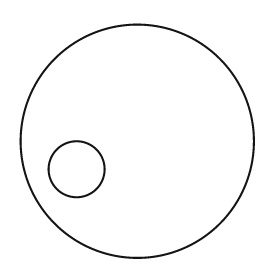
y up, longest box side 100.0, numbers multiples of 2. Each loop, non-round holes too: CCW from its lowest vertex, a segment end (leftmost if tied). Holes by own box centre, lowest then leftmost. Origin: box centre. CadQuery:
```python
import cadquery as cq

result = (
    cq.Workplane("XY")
    .moveTo(0.0, 0.0)
    .circle(50.0)
    .moveTo(-26.0, -12.0)
    .circle(12.0)
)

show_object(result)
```